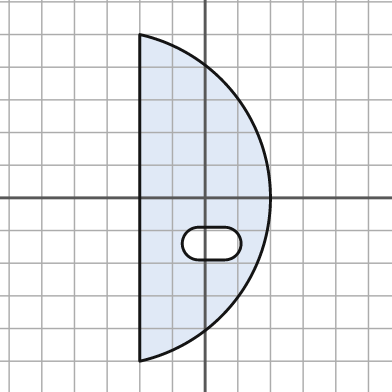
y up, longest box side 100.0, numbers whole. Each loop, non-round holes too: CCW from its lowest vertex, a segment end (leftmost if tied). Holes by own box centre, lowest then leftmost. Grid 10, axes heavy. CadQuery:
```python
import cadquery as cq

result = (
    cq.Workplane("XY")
    .moveTo(-20.0, -50.0)
    .threePointArc((20.0, 0.0), (-20.0, 50.0))
    .close()
    .moveTo(-2.0, -19.0)
    .lineTo(6.0, -19.0)
    .threePointArc((11.0, -14.0), (6.0, -9.0))
    .lineTo(-2.0, -9.0)
    .threePointArc((-7.0, -14.0), (-2.0, -19.0))
    .close()
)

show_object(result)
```